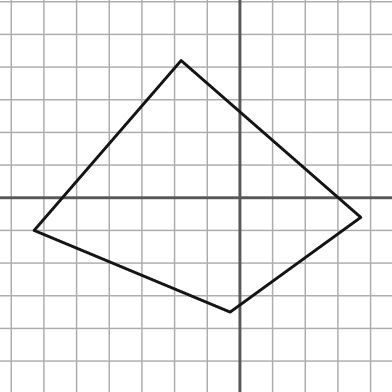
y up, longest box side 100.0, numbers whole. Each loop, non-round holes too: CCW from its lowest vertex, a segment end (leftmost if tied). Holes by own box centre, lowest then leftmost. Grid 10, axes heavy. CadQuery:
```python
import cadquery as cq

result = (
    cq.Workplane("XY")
    .moveTo(-3.0, -35.0)
    .lineTo(37.0, -6.0)
    .lineTo(-18.0, 42.0)
    .lineTo(-63.0, -10.0)
    .close()
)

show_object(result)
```